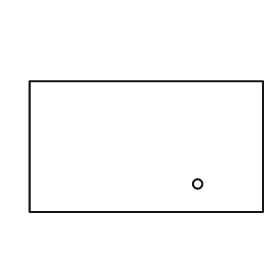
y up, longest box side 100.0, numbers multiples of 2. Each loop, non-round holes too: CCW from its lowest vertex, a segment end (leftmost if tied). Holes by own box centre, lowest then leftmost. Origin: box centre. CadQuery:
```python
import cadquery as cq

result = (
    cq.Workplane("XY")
    .moveTo(-50.0, -28.0)
    .lineTo(50.0, -28.0)
    .lineTo(50.0, 28.0)
    .lineTo(-50.0, 28.0)
    .close()
    .moveTo(22.0, -16.0)
    .circle(2.0)
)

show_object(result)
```